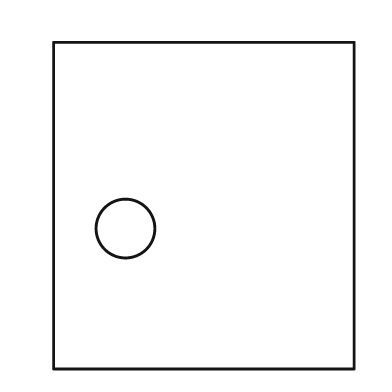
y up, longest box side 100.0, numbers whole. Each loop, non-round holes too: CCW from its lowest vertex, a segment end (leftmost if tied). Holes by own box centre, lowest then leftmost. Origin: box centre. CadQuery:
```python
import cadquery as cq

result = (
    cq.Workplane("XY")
    .moveTo(-46.0, -50.0)
    .lineTo(46.0, -50.0)
    .lineTo(46.0, 50.0)
    .lineTo(-46.0, 50.0)
    .close()
    .moveTo(-24.0, -7.0)
    .circle(9.0)
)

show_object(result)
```